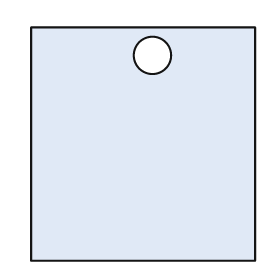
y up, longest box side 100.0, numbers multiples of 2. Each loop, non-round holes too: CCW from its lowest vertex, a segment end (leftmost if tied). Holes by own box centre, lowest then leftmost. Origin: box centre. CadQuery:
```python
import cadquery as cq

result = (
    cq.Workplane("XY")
    .moveTo(-48.0, -50.0)
    .lineTo(48.0, -50.0)
    .lineTo(48.0, 50.0)
    .lineTo(-48.0, 50.0)
    .close()
    .moveTo(4.0, 38.0)
    .circle(8.0)
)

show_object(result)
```